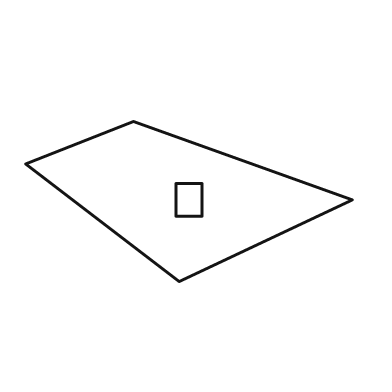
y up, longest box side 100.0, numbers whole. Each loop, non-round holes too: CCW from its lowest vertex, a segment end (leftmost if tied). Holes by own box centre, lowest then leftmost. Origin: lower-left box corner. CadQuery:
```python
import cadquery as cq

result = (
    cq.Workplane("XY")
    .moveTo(47.0, 0.0)
    .lineTo(100.0, 25.0)
    .lineTo(33.0, 49.0)
    .lineTo(0.0, 36.0)
    .close()
    .moveTo(46.0, 20.0)
    .lineTo(54.0, 20.0)
    .lineTo(54.0, 30.0)
    .lineTo(46.0, 30.0)
    .close()
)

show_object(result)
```